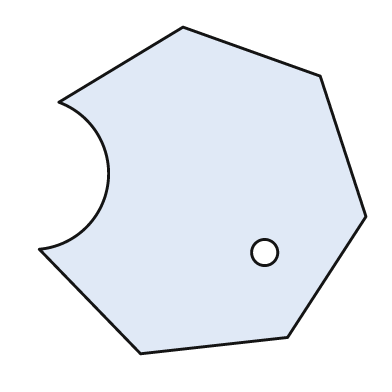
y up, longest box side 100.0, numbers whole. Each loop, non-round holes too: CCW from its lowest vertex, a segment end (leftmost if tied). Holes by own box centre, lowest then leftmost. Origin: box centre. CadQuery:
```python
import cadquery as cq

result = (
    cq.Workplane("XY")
    .moveTo(-19.0, -50.0)
    .lineTo(26.0, -45.0)
    .lineTo(50.0, -8.0)
    .lineTo(36.0, 35.0)
    .lineTo(-6.0, 50.0)
    .lineTo(-44.0, 27.0)
    .threePointArc((-29.0, 2.0), (-50.0, -18.0))
    .close()
    .moveTo(19.0, -19.0)
    .circle(4.0)
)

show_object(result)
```